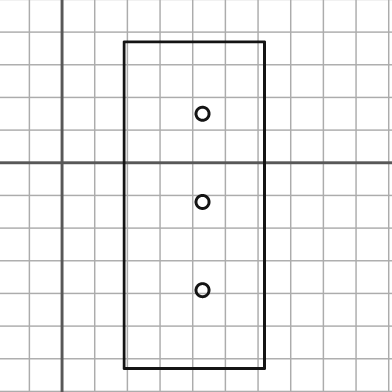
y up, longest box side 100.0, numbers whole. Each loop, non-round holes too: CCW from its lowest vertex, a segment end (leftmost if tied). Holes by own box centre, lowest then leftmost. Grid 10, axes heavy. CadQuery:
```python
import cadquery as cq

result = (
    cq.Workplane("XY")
    .moveTo(19.0, -63.0)
    .lineTo(62.0, -63.0)
    .lineTo(62.0, 37.0)
    .lineTo(19.0, 37.0)
    .close()
    .moveTo(43.0, -39.0)
    .circle(2.0)
    .moveTo(43.0, -12.0)
    .circle(2.0)
    .moveTo(43.0, 15.0)
    .circle(2.0)
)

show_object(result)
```